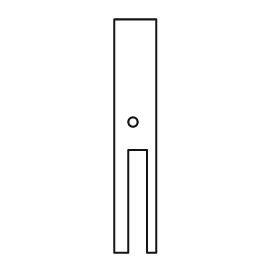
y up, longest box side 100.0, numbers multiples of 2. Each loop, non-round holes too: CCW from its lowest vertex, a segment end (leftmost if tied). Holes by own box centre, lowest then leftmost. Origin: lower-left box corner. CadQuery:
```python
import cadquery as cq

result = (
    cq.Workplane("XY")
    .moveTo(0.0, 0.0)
    .lineTo(6.0, 0.0)
    .lineTo(6.0, 44.0)
    .lineTo(14.0, 44.0)
    .lineTo(14.0, 0.0)
    .lineTo(18.0, 0.0)
    .lineTo(18.0, 100.0)
    .lineTo(0.0, 100.0)
    .close()
    .moveTo(8.0, 56.0)
    .circle(2.0)
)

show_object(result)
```